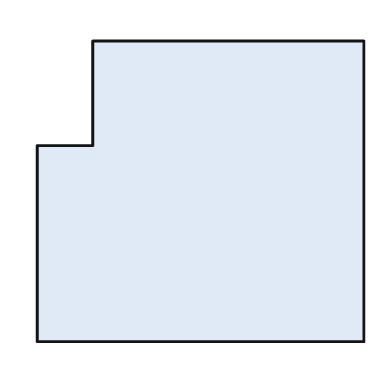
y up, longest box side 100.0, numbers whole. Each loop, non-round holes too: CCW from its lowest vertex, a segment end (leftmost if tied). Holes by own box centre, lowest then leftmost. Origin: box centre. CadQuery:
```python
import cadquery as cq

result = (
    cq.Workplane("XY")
    .moveTo(-50.0, -46.0)
    .lineTo(50.0, -46.0)
    .lineTo(50.0, 46.0)
    .lineTo(-33.0, 46.0)
    .lineTo(-33.0, 14.0)
    .lineTo(-50.0, 14.0)
    .close()
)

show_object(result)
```